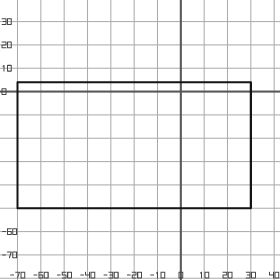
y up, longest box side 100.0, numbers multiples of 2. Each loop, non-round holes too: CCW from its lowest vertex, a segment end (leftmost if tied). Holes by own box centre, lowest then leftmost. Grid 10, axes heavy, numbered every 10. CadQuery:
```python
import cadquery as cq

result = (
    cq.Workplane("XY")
    .moveTo(-70.0, -50.0)
    .lineTo(30.0, -50.0)
    .lineTo(30.0, 4.0)
    .lineTo(-70.0, 4.0)
    .close()
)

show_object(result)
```